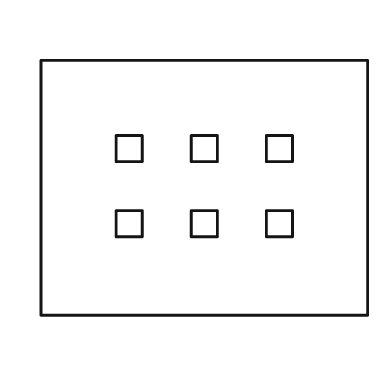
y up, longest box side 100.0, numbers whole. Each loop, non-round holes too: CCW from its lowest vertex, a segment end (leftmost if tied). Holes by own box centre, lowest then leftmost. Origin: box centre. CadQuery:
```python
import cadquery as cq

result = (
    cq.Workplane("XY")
    .moveTo(-50.0, -39.0)
    .lineTo(50.0, -39.0)
    .lineTo(50.0, 39.0)
    .lineTo(-50.0, 39.0)
    .close()
    .moveTo(-27.0, -15.0)
    .lineTo(-19.0, -15.0)
    .lineTo(-19.0, -7.0)
    .lineTo(-27.0, -7.0)
    .close()
    .moveTo(-4.0, -15.0)
    .lineTo(4.0, -15.0)
    .lineTo(4.0, -7.0)
    .lineTo(-4.0, -7.0)
    .close()
    .moveTo(19.0, -15.0)
    .lineTo(27.0, -15.0)
    .lineTo(27.0, -7.0)
    .lineTo(19.0, -7.0)
    .close()
    .moveTo(-27.0, 8.0)
    .lineTo(-19.0, 8.0)
    .lineTo(-19.0, 16.0)
    .lineTo(-27.0, 16.0)
    .close()
    .moveTo(-4.0, 8.0)
    .lineTo(4.0, 8.0)
    .lineTo(4.0, 16.0)
    .lineTo(-4.0, 16.0)
    .close()
    .moveTo(19.0, 8.0)
    .lineTo(27.0, 8.0)
    .lineTo(27.0, 16.0)
    .lineTo(19.0, 16.0)
    .close()
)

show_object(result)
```